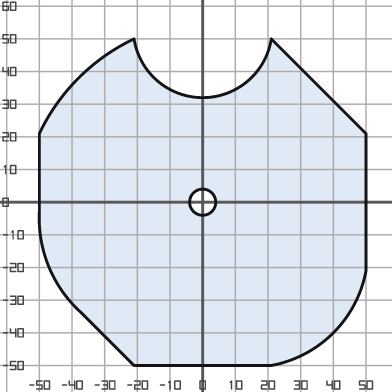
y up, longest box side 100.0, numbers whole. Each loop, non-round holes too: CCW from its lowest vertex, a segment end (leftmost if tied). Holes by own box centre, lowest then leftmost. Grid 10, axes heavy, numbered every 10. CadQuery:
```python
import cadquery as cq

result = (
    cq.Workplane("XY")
    .moveTo(-21.0, -50.0)
    .lineTo(21.0, -50.0)
    .threePointArc((40.0, -40.0), (50.0, -21.0))
    .lineTo(50.0, 21.0)
    .lineTo(21.0, 50.0)
    .threePointArc((0.0, 32.0), (-21.0, 50.0))
    .threePointArc((-38.0, 38.0), (-50.0, 21.0))
    .lineTo(-50.0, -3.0)
    .threePointArc((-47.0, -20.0), (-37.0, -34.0))
    .close()
    .moveTo(0.0, 0.0)
    .circle(4.0)
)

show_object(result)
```